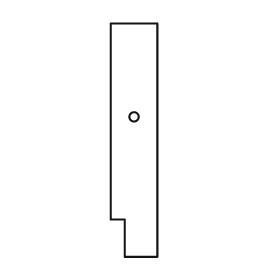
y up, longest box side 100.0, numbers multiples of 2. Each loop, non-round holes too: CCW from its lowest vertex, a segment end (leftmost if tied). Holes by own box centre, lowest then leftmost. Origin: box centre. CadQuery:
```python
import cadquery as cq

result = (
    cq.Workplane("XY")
    .moveTo(-4.0, -50.0)
    .lineTo(10.0, -50.0)
    .lineTo(10.0, 50.0)
    .lineTo(-10.0, 50.0)
    .lineTo(-10.0, -34.0)
    .lineTo(-4.0, -34.0)
    .close()
    .moveTo(0.0, 10.0)
    .circle(2.0)
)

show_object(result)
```